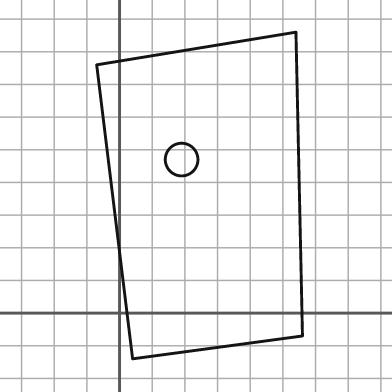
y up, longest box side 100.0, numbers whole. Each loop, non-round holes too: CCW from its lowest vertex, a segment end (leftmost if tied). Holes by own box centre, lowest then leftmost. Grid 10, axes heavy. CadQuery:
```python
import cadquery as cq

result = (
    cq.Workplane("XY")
    .moveTo(4.0, -14.0)
    .lineTo(56.0, -7.0)
    .lineTo(54.0, 86.0)
    .lineTo(-7.0, 76.0)
    .close()
    .moveTo(19.0, 47.0)
    .circle(5.0)
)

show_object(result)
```